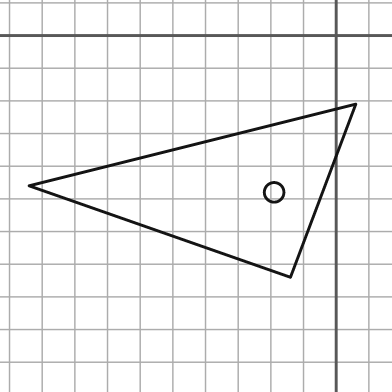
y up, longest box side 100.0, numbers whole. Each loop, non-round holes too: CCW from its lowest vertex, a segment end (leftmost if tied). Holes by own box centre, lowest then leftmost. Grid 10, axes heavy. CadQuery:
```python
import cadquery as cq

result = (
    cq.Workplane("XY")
    .moveTo(-14.0, -74.0)
    .lineTo(6.0, -21.0)
    .lineTo(-94.0, -46.0)
    .close()
    .moveTo(-19.0, -48.0)
    .circle(3.0)
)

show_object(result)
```